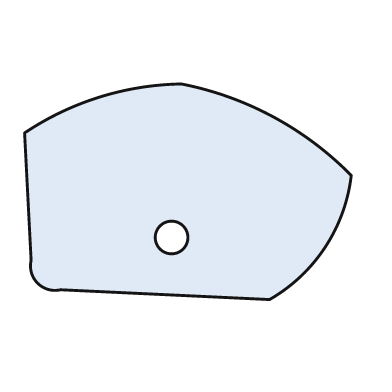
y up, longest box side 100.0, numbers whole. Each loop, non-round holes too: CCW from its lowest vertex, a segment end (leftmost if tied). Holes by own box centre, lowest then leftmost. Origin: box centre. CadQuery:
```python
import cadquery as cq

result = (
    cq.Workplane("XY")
    .moveTo(25.0, -33.0)
    .threePointArc((42.0, -17.0), (50.0, 5.0))
    .threePointArc((26.0, 23.0), (-2.0, 33.0))
    .threePointArc((-27.0, 29.0), (-50.0, 18.0))
    .lineTo(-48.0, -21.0)
    .threePointArc((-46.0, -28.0), (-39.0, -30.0))
    .close()
    .moveTo(-5.0, -14.0)
    .circle(5.0)
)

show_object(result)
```